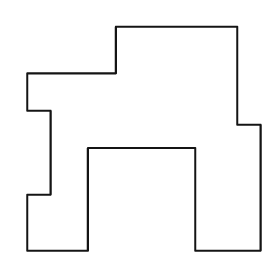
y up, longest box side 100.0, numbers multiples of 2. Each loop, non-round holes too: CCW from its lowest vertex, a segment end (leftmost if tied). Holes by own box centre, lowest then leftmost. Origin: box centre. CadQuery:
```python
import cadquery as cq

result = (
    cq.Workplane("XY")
    .moveTo(-50.0, -48.0)
    .lineTo(-24.0, -48.0)
    .lineTo(-24.0, -4.0)
    .lineTo(22.0, -4.0)
    .lineTo(22.0, -48.0)
    .lineTo(50.0, -48.0)
    .lineTo(50.0, 6.0)
    .lineTo(40.0, 6.0)
    .lineTo(40.0, 48.0)
    .lineTo(-12.0, 48.0)
    .lineTo(-12.0, 28.0)
    .lineTo(-50.0, 28.0)
    .lineTo(-50.0, 12.0)
    .lineTo(-40.0, 12.0)
    .lineTo(-40.0, -24.0)
    .lineTo(-50.0, -24.0)
    .close()
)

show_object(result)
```